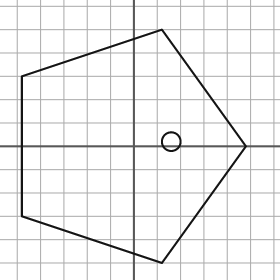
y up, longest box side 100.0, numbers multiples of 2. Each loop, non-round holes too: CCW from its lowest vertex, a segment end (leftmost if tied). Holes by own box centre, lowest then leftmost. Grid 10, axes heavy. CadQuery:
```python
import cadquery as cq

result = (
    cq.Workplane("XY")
    .moveTo(12.0, -50.0)
    .lineTo(48.0, 0.0)
    .lineTo(12.0, 50.0)
    .lineTo(-48.0, 30.0)
    .lineTo(-48.0, -30.0)
    .close()
    .moveTo(16.0, 2.0)
    .circle(4.0)
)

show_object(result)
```